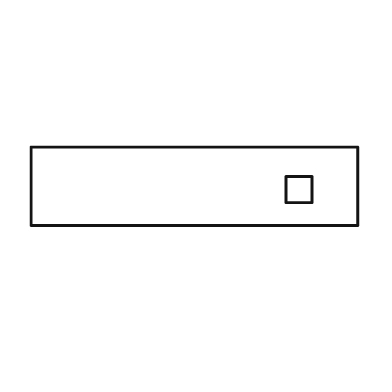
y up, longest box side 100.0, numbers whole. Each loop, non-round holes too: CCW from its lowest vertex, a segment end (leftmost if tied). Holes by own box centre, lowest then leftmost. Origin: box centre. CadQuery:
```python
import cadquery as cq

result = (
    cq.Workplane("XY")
    .moveTo(-50.0, -12.0)
    .lineTo(50.0, -12.0)
    .lineTo(50.0, 12.0)
    .lineTo(-50.0, 12.0)
    .close()
    .moveTo(28.0, -5.0)
    .lineTo(36.0, -5.0)
    .lineTo(36.0, 3.0)
    .lineTo(28.0, 3.0)
    .close()
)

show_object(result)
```